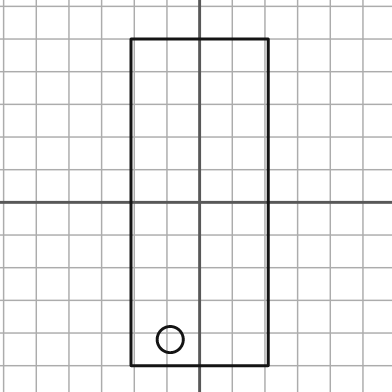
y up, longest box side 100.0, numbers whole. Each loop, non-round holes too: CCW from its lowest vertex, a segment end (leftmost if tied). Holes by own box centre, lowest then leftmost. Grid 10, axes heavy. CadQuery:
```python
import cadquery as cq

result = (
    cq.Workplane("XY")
    .moveTo(-21.0, -50.0)
    .lineTo(21.0, -50.0)
    .lineTo(21.0, 50.0)
    .lineTo(-21.0, 50.0)
    .close()
    .moveTo(-9.0, -42.0)
    .circle(4.0)
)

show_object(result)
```